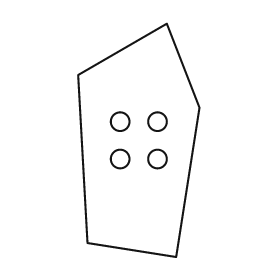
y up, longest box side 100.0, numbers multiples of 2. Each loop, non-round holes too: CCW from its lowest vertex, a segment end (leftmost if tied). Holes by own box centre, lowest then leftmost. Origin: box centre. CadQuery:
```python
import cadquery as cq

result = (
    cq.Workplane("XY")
    .moveTo(16.0, -50.0)
    .lineTo(26.0, 14.0)
    .lineTo(12.0, 50.0)
    .lineTo(-26.0, 28.0)
    .lineTo(-22.0, -44.0)
    .close()
    .moveTo(-8.0, -8.0)
    .circle(4.0)
    .moveTo(8.0, -8.0)
    .circle(4.0)
    .moveTo(-8.0, 8.0)
    .circle(4.0)
    .moveTo(8.0, 8.0)
    .circle(4.0)
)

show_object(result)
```